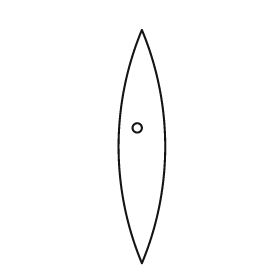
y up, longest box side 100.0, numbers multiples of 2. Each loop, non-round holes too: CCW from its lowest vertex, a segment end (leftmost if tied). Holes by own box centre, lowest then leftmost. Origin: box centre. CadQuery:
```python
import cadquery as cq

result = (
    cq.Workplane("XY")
    .moveTo(0.0, -50.0)
    .threePointArc((10.0, 0.0), (0.0, 50.0))
    .threePointArc((-10.0, 0.0), (0.0, -50.0))
    .close()
    .moveTo(-2.0, 8.0)
    .circle(2.0)
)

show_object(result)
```